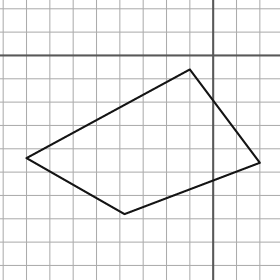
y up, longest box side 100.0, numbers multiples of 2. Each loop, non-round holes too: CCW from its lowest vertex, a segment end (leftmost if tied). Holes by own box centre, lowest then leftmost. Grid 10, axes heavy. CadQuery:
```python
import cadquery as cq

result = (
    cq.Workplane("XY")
    .moveTo(-38.0, -68.0)
    .lineTo(20.0, -46.0)
    .lineTo(-10.0, -6.0)
    .lineTo(-80.0, -44.0)
    .close()
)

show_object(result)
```